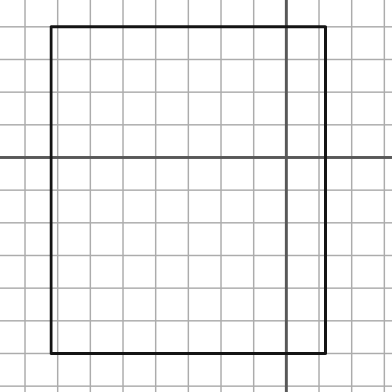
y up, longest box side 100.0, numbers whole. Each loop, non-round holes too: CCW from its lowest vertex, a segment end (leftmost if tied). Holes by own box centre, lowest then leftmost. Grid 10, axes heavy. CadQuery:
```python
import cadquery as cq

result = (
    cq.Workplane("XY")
    .moveTo(-72.0, -60.0)
    .lineTo(12.0, -60.0)
    .lineTo(12.0, 40.0)
    .lineTo(-72.0, 40.0)
    .close()
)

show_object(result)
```